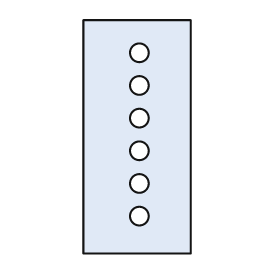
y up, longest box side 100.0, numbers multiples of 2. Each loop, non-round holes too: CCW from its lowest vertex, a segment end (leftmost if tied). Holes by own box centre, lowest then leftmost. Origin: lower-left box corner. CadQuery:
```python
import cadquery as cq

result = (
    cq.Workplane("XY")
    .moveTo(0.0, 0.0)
    .lineTo(46.0, 0.0)
    .lineTo(46.0, 100.0)
    .lineTo(0.0, 100.0)
    .close()
    .moveTo(24.0, 16.0)
    .circle(4.0)
    .moveTo(24.0, 30.0)
    .circle(4.0)
    .moveTo(24.0, 44.0)
    .circle(4.0)
    .moveTo(24.0, 58.0)
    .circle(4.0)
    .moveTo(24.0, 72.0)
    .circle(4.0)
    .moveTo(24.0, 86.0)
    .circle(4.0)
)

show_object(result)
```